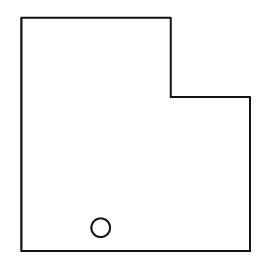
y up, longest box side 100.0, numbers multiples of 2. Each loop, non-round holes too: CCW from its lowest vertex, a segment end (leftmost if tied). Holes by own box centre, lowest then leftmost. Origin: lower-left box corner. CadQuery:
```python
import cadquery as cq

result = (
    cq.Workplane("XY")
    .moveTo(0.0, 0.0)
    .lineTo(98.0, 0.0)
    .lineTo(98.0, 66.0)
    .lineTo(64.0, 66.0)
    .lineTo(64.0, 100.0)
    .lineTo(0.0, 100.0)
    .close()
    .moveTo(34.0, 10.0)
    .circle(4.0)
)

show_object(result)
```